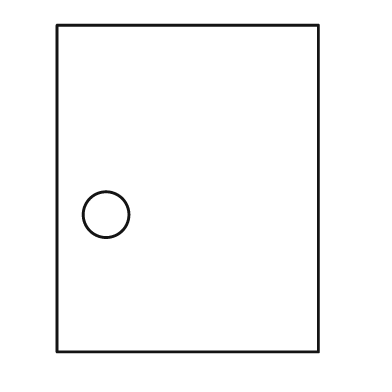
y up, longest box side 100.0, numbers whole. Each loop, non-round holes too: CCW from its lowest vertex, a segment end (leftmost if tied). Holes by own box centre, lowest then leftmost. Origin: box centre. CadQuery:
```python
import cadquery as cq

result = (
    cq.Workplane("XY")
    .moveTo(-40.0, -50.0)
    .lineTo(40.0, -50.0)
    .lineTo(40.0, 50.0)
    .lineTo(-40.0, 50.0)
    .close()
    .moveTo(-25.0, -8.0)
    .circle(7.0)
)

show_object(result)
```